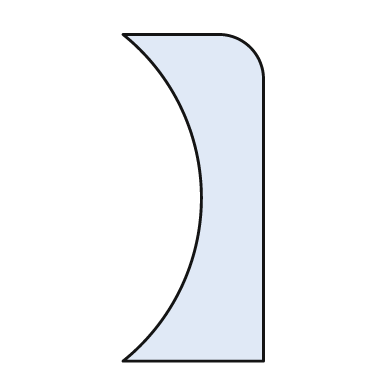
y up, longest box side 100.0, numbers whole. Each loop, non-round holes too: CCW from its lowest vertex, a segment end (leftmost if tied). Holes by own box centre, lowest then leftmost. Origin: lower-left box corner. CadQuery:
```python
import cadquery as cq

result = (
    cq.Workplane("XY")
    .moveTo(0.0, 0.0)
    .lineTo(43.0, 0.0)
    .lineTo(43.0, 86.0)
    .threePointArc((39.0, 96.0), (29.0, 100.0))
    .lineTo(0.0, 100.0)
    .threePointArc((24.0, 50.0), (0.0, 0.0))
    .close()
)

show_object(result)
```